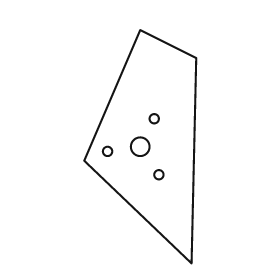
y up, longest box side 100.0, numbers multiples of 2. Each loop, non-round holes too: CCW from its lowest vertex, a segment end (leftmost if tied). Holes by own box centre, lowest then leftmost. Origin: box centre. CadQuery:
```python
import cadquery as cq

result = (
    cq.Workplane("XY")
    .moveTo(22.0, -50.0)
    .lineTo(24.0, 38.0)
    .lineTo(0.0, 50.0)
    .lineTo(-24.0, -6.0)
    .close()
    .moveTo(8.0, -12.0)
    .circle(2.0)
    .moveTo(-14.0, -2.0)
    .circle(2.0)
    .moveTo(0.0, 0.0)
    .circle(4.0)
    .moveTo(6.0, 12.0)
    .circle(2.0)
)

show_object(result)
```